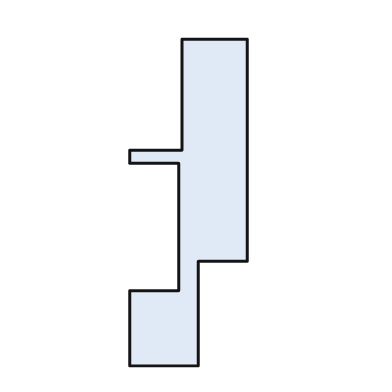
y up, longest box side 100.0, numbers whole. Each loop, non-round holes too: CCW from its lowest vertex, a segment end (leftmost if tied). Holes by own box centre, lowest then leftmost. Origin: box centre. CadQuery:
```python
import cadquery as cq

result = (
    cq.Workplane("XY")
    .moveTo(-18.0, -50.0)
    .lineTo(3.0, -50.0)
    .lineTo(3.0, -18.0)
    .lineTo(18.0, -18.0)
    .lineTo(18.0, 50.0)
    .lineTo(-2.0, 50.0)
    .lineTo(-2.0, 16.0)
    .lineTo(-18.0, 16.0)
    .lineTo(-18.0, 12.0)
    .lineTo(-3.0, 12.0)
    .lineTo(-3.0, -27.0)
    .lineTo(-18.0, -27.0)
    .close()
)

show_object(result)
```